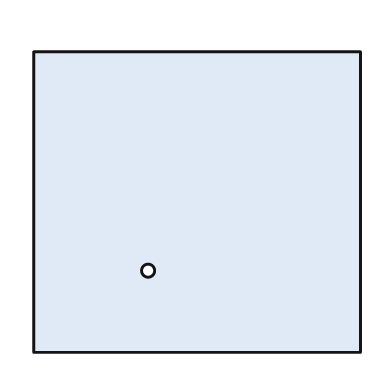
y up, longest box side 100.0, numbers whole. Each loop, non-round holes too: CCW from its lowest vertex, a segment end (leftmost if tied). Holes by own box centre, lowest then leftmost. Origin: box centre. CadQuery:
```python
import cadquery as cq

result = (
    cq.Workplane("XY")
    .moveTo(-50.0, -46.0)
    .lineTo(50.0, -46.0)
    .lineTo(50.0, 46.0)
    .lineTo(-50.0, 46.0)
    .close()
    .moveTo(-15.0, -21.0)
    .circle(2.0)
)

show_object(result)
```